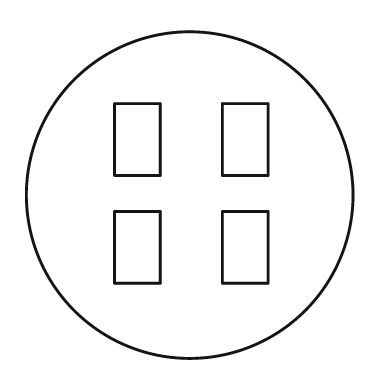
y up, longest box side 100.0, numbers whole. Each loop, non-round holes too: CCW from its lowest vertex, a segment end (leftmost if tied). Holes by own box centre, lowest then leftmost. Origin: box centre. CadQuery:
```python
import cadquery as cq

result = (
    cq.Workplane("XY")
    .moveTo(0.0, 0.0)
    .circle(50.0)
    .moveTo(-23.0, -27.0)
    .lineTo(-9.0, -27.0)
    .lineTo(-9.0, -5.0)
    .lineTo(-23.0, -5.0)
    .close()
    .moveTo(10.0, -27.0)
    .lineTo(24.0, -27.0)
    .lineTo(24.0, -5.0)
    .lineTo(10.0, -5.0)
    .close()
    .moveTo(-23.0, 6.0)
    .lineTo(-9.0, 6.0)
    .lineTo(-9.0, 28.0)
    .lineTo(-23.0, 28.0)
    .close()
    .moveTo(10.0, 6.0)
    .lineTo(24.0, 6.0)
    .lineTo(24.0, 28.0)
    .lineTo(10.0, 28.0)
    .close()
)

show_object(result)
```